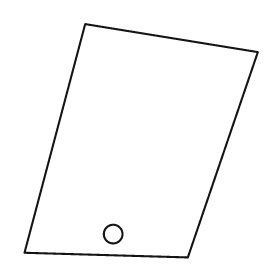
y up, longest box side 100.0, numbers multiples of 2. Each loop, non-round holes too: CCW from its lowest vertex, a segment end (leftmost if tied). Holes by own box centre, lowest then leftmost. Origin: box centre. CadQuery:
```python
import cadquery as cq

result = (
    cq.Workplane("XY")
    .moveTo(20.0, -50.0)
    .lineTo(50.0, 38.0)
    .lineTo(-24.0, 50.0)
    .lineTo(-50.0, -48.0)
    .close()
    .moveTo(-12.0, -40.0)
    .circle(4.0)
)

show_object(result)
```